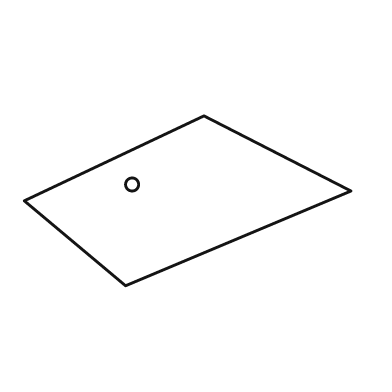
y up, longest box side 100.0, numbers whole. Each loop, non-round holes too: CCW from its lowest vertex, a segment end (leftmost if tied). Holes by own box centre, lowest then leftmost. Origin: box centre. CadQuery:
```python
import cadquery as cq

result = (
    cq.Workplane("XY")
    .moveTo(-19.0, -26.0)
    .lineTo(50.0, 3.0)
    .lineTo(5.0, 26.0)
    .lineTo(-50.0, 0.0)
    .close()
    .moveTo(-17.0, 5.0)
    .circle(2.0)
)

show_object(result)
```